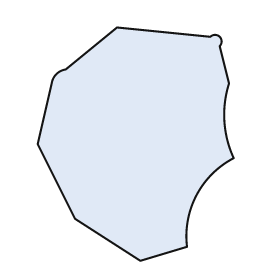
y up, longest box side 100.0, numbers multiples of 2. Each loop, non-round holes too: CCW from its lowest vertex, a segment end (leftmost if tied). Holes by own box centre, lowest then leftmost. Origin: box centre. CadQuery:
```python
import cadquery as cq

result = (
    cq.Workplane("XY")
    .moveTo(2.0, -50.0)
    .lineTo(22.0, -44.0)
    .threePointArc((26.0, -22.0), (42.0, -6.0))
    .threePointArc((38.0, 10.0), (40.0, 26.0))
    .lineTo(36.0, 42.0)
    .threePointArc((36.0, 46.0), (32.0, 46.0))
    .lineTo(-8.0, 50.0)
    .lineTo(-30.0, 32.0)
    .threePointArc((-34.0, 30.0), (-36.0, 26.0))
    .lineTo(-42.0, 0.0)
    .lineTo(-26.0, -32.0)
    .close()
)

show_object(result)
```